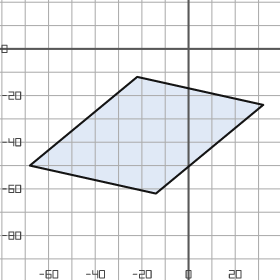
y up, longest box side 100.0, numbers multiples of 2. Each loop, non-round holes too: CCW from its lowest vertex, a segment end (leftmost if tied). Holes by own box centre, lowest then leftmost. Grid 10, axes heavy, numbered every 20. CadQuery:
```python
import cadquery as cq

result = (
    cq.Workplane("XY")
    .moveTo(-14.0, -62.0)
    .lineTo(32.0, -24.0)
    .lineTo(-22.0, -12.0)
    .lineTo(-68.0, -50.0)
    .close()
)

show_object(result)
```